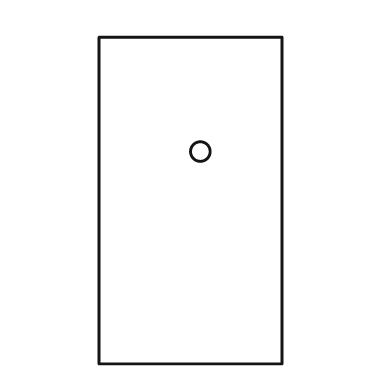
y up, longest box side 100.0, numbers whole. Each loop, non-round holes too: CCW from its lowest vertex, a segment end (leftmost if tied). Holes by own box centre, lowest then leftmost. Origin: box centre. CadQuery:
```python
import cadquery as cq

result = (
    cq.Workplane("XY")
    .moveTo(-28.0, -50.0)
    .lineTo(28.0, -50.0)
    .lineTo(28.0, 50.0)
    .lineTo(-28.0, 50.0)
    .close()
    .moveTo(3.0, 15.0)
    .circle(3.0)
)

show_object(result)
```